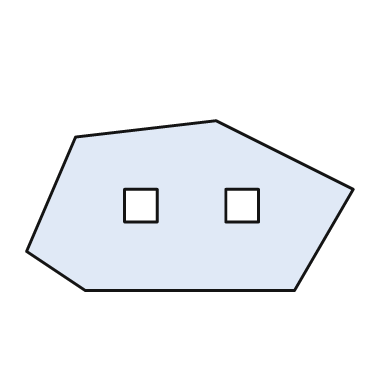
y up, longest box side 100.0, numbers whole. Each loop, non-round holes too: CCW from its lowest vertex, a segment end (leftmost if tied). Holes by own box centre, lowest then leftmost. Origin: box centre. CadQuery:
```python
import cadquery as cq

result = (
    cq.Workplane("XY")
    .moveTo(-32.0, -26.0)
    .lineTo(32.0, -26.0)
    .lineTo(50.0, 5.0)
    .lineTo(8.0, 26.0)
    .lineTo(-35.0, 21.0)
    .lineTo(-50.0, -14.0)
    .close()
    .moveTo(-20.0, -5.0)
    .lineTo(-10.0, -5.0)
    .lineTo(-10.0, 5.0)
    .lineTo(-20.0, 5.0)
    .close()
    .moveTo(11.0, -5.0)
    .lineTo(21.0, -5.0)
    .lineTo(21.0, 5.0)
    .lineTo(11.0, 5.0)
    .close()
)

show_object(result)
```